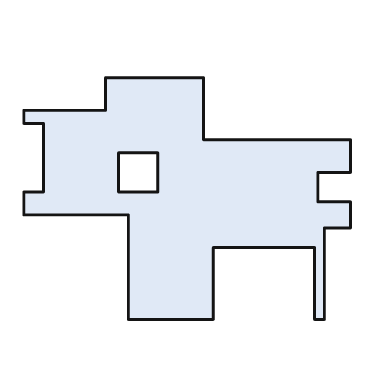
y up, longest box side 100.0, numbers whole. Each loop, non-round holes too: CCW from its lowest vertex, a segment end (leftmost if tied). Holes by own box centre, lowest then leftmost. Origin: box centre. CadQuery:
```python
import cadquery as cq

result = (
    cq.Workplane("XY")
    .moveTo(-18.0, -37.0)
    .lineTo(8.0, -37.0)
    .lineTo(8.0, -15.0)
    .lineTo(39.0, -15.0)
    .lineTo(39.0, -37.0)
    .lineTo(42.0, -37.0)
    .lineTo(42.0, -9.0)
    .lineTo(50.0, -9.0)
    .lineTo(50.0, -1.0)
    .lineTo(40.0, -1.0)
    .lineTo(40.0, 8.0)
    .lineTo(50.0, 8.0)
    .lineTo(50.0, 18.0)
    .lineTo(5.0, 18.0)
    .lineTo(5.0, 37.0)
    .lineTo(-25.0, 37.0)
    .lineTo(-25.0, 27.0)
    .lineTo(-50.0, 27.0)
    .lineTo(-50.0, 23.0)
    .lineTo(-44.0, 23.0)
    .lineTo(-44.0, 2.0)
    .lineTo(-50.0, 2.0)
    .lineTo(-50.0, -5.0)
    .lineTo(-18.0, -5.0)
    .close()
    .moveTo(-21.0, 2.0)
    .lineTo(-9.0, 2.0)
    .lineTo(-9.0, 14.0)
    .lineTo(-21.0, 14.0)
    .close()
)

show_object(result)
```